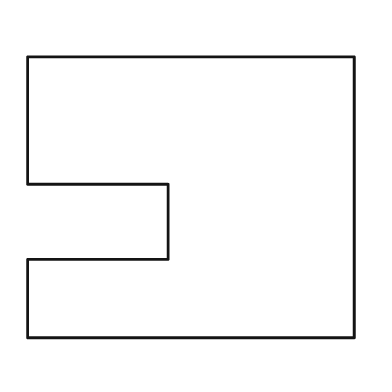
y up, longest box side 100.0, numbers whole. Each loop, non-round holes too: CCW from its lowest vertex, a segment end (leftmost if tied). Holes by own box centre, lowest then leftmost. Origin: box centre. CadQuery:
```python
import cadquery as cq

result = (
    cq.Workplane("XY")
    .moveTo(-50.0, -43.0)
    .lineTo(50.0, -43.0)
    .lineTo(50.0, 43.0)
    .lineTo(-50.0, 43.0)
    .lineTo(-50.0, 4.0)
    .lineTo(-7.0, 4.0)
    .lineTo(-7.0, -19.0)
    .lineTo(-50.0, -19.0)
    .close()
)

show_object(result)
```